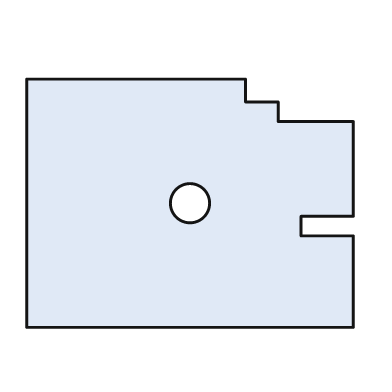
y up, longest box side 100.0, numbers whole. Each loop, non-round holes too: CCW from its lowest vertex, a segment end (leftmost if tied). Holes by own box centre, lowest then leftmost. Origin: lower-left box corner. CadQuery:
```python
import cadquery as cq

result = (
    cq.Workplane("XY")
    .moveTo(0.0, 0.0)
    .lineTo(100.0, 0.0)
    .lineTo(100.0, 28.0)
    .lineTo(84.0, 28.0)
    .lineTo(84.0, 34.0)
    .lineTo(100.0, 34.0)
    .lineTo(100.0, 63.0)
    .lineTo(77.0, 63.0)
    .lineTo(77.0, 69.0)
    .lineTo(67.0, 69.0)
    .lineTo(67.0, 76.0)
    .lineTo(0.0, 76.0)
    .close()
    .moveTo(50.0, 38.0)
    .circle(6.0)
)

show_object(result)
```